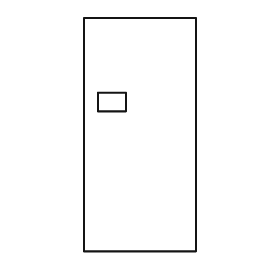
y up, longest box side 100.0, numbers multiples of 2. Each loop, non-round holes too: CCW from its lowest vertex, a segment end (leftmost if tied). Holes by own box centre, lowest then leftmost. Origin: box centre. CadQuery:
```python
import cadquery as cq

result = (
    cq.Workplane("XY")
    .moveTo(-24.0, -50.0)
    .lineTo(24.0, -50.0)
    .lineTo(24.0, 50.0)
    .lineTo(-24.0, 50.0)
    .close()
    .moveTo(-18.0, 10.0)
    .lineTo(-6.0, 10.0)
    .lineTo(-6.0, 18.0)
    .lineTo(-18.0, 18.0)
    .close()
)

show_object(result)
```